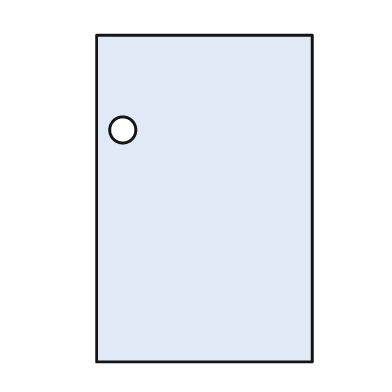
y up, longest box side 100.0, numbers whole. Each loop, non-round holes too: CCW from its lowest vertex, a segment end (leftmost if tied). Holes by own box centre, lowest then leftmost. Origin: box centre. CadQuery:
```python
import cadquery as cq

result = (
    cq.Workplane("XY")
    .moveTo(-33.0, -50.0)
    .lineTo(33.0, -50.0)
    .lineTo(33.0, 50.0)
    .lineTo(-33.0, 50.0)
    .close()
    .moveTo(-25.0, 21.0)
    .circle(4.0)
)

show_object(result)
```